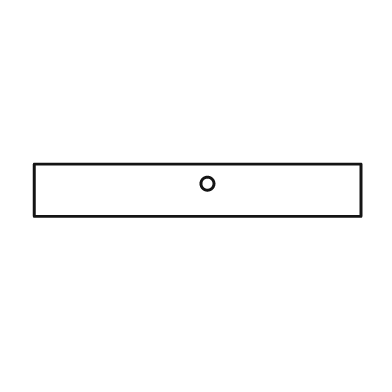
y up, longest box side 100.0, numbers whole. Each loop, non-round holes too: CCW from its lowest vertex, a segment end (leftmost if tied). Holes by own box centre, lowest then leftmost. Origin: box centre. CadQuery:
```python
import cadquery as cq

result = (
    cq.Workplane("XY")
    .moveTo(-50.0, -8.0)
    .lineTo(50.0, -8.0)
    .lineTo(50.0, 8.0)
    .lineTo(-50.0, 8.0)
    .close()
    .moveTo(3.0, 2.0)
    .circle(2.0)
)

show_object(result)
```